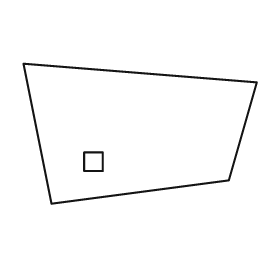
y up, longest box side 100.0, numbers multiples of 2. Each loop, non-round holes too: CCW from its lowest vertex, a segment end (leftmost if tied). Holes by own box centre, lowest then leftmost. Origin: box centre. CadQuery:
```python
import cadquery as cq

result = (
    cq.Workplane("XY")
    .moveTo(-38.0, -30.0)
    .lineTo(38.0, -20.0)
    .lineTo(50.0, 22.0)
    .lineTo(-50.0, 30.0)
    .close()
    .moveTo(-24.0, -16.0)
    .lineTo(-16.0, -16.0)
    .lineTo(-16.0, -8.0)
    .lineTo(-24.0, -8.0)
    .close()
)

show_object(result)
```